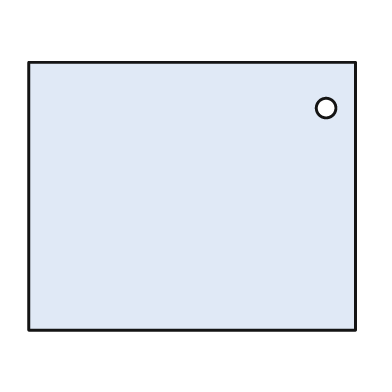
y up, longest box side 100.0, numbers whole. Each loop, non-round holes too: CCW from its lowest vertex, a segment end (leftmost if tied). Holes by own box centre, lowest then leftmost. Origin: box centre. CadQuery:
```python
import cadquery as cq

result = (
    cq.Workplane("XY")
    .moveTo(-50.0, -41.0)
    .lineTo(50.0, -41.0)
    .lineTo(50.0, 41.0)
    .lineTo(-50.0, 41.0)
    .close()
    .moveTo(41.0, 27.0)
    .circle(3.0)
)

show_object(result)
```